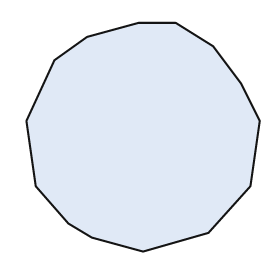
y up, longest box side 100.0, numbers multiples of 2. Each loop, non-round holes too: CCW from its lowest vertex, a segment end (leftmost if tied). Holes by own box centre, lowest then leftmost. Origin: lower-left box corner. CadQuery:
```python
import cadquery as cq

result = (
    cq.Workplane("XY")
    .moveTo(50.0, 0.0)
    .lineTo(78.0, 8.0)
    .lineTo(96.0, 28.0)
    .lineTo(100.0, 56.0)
    .lineTo(92.0, 72.0)
    .lineTo(80.0, 88.0)
    .lineTo(64.0, 98.0)
    .lineTo(48.0, 98.0)
    .lineTo(26.0, 92.0)
    .lineTo(12.0, 82.0)
    .lineTo(0.0, 56.0)
    .lineTo(4.0, 28.0)
    .lineTo(18.0, 12.0)
    .lineTo(28.0, 6.0)
    .close()
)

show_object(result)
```